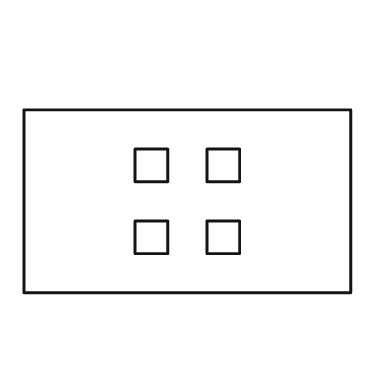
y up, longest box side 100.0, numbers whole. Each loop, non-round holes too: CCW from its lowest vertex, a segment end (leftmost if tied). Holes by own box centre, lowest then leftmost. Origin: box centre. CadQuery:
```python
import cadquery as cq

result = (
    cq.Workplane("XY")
    .moveTo(-50.0, -28.0)
    .lineTo(50.0, -28.0)
    .lineTo(50.0, 28.0)
    .lineTo(-50.0, 28.0)
    .close()
    .moveTo(-16.0, -16.0)
    .lineTo(-6.0, -16.0)
    .lineTo(-6.0, -6.0)
    .lineTo(-16.0, -6.0)
    .close()
    .moveTo(6.0, -16.0)
    .lineTo(16.0, -16.0)
    .lineTo(16.0, -6.0)
    .lineTo(6.0, -6.0)
    .close()
    .moveTo(-16.0, 6.0)
    .lineTo(-6.0, 6.0)
    .lineTo(-6.0, 16.0)
    .lineTo(-16.0, 16.0)
    .close()
    .moveTo(6.0, 6.0)
    .lineTo(16.0, 6.0)
    .lineTo(16.0, 16.0)
    .lineTo(6.0, 16.0)
    .close()
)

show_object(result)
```